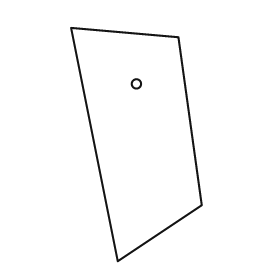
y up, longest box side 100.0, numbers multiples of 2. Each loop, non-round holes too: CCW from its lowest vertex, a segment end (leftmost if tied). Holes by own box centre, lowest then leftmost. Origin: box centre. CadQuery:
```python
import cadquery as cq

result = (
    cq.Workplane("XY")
    .moveTo(-8.0, -50.0)
    .lineTo(28.0, -26.0)
    .lineTo(18.0, 46.0)
    .lineTo(-28.0, 50.0)
    .close()
    .moveTo(0.0, 26.0)
    .circle(2.0)
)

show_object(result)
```